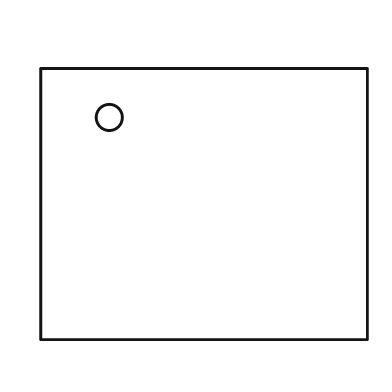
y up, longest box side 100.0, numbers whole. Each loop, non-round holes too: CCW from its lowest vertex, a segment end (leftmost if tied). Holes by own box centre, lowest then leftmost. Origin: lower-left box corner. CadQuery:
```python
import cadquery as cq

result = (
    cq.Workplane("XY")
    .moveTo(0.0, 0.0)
    .lineTo(100.0, 0.0)
    .lineTo(100.0, 83.0)
    .lineTo(0.0, 83.0)
    .close()
    .moveTo(21.0, 68.0)
    .circle(4.0)
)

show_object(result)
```